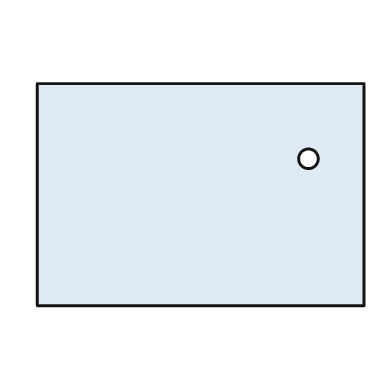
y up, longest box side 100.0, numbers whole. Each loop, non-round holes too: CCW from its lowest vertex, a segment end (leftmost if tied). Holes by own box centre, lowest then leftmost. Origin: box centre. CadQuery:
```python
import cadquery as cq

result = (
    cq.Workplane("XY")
    .moveTo(-50.0, -34.0)
    .lineTo(50.0, -34.0)
    .lineTo(50.0, 34.0)
    .lineTo(-50.0, 34.0)
    .close()
    .moveTo(33.0, 11.0)
    .circle(3.0)
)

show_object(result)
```